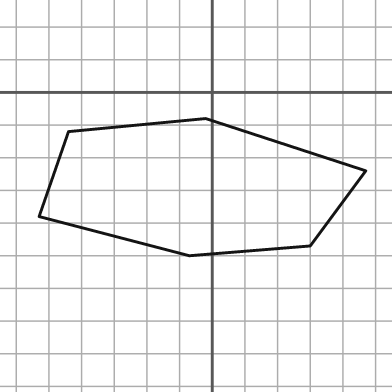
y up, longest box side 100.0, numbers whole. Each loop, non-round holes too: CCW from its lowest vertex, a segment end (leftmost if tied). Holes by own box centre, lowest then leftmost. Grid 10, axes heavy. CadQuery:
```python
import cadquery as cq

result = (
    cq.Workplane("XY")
    .moveTo(-7.0, -50.0)
    .lineTo(30.0, -47.0)
    .lineTo(47.0, -24.0)
    .lineTo(-2.0, -8.0)
    .lineTo(-44.0, -12.0)
    .lineTo(-53.0, -38.0)
    .close()
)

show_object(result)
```